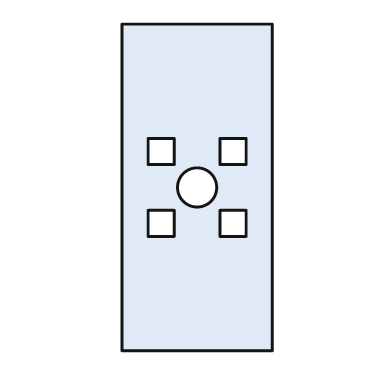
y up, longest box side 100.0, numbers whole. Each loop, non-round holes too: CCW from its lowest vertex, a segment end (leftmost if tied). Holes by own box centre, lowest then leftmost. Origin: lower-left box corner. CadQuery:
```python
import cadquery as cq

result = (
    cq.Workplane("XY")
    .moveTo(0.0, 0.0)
    .lineTo(46.0, 0.0)
    .lineTo(46.0, 100.0)
    .lineTo(0.0, 100.0)
    .close()
    .moveTo(8.0, 35.0)
    .lineTo(16.0, 35.0)
    .lineTo(16.0, 43.0)
    .lineTo(8.0, 43.0)
    .close()
    .moveTo(30.0, 35.0)
    .lineTo(38.0, 35.0)
    .lineTo(38.0, 43.0)
    .lineTo(30.0, 43.0)
    .close()
    .moveTo(23.0, 50.0)
    .circle(6.0)
    .moveTo(8.0, 57.0)
    .lineTo(16.0, 57.0)
    .lineTo(16.0, 65.0)
    .lineTo(8.0, 65.0)
    .close()
    .moveTo(30.0, 57.0)
    .lineTo(38.0, 57.0)
    .lineTo(38.0, 65.0)
    .lineTo(30.0, 65.0)
    .close()
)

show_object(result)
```